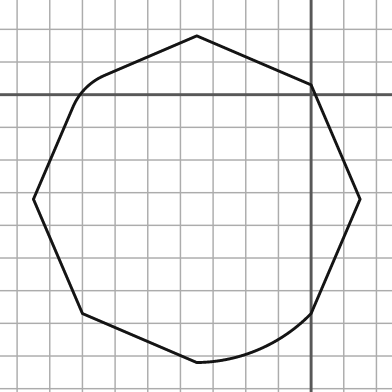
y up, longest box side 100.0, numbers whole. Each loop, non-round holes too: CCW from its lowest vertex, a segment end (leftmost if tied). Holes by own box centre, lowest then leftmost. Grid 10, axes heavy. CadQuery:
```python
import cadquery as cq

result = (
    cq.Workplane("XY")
    .moveTo(-35.0, -82.0)
    .threePointArc((-16.0, -78.0), (0.0, -67.0))
    .lineTo(15.0, -32.0)
    .lineTo(0.0, 3.0)
    .lineTo(-35.0, 18.0)
    .lineTo(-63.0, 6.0)
    .threePointArc((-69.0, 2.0), (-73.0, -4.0))
    .lineTo(-85.0, -32.0)
    .lineTo(-70.0, -67.0)
    .close()
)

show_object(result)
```